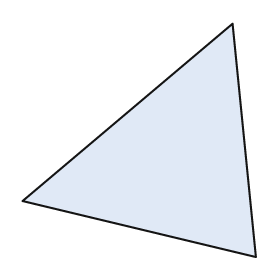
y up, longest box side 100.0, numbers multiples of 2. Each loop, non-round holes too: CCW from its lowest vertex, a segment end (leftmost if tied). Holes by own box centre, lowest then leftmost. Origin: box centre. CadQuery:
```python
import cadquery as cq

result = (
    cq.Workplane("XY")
    .moveTo(50.0, -50.0)
    .lineTo(40.0, 50.0)
    .lineTo(-50.0, -26.0)
    .close()
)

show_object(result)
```